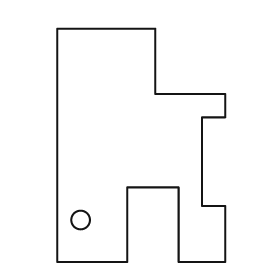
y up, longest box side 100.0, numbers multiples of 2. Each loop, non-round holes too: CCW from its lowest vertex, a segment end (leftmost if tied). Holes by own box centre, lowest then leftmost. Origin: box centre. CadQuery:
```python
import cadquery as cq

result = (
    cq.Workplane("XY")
    .moveTo(-36.0, -50.0)
    .lineTo(-6.0, -50.0)
    .lineTo(-6.0, -18.0)
    .lineTo(16.0, -18.0)
    .lineTo(16.0, -50.0)
    .lineTo(36.0, -50.0)
    .lineTo(36.0, -26.0)
    .lineTo(26.0, -26.0)
    .lineTo(26.0, 12.0)
    .lineTo(36.0, 12.0)
    .lineTo(36.0, 22.0)
    .lineTo(6.0, 22.0)
    .lineTo(6.0, 50.0)
    .lineTo(-36.0, 50.0)
    .close()
    .moveTo(-26.0, -32.0)
    .circle(4.0)
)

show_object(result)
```